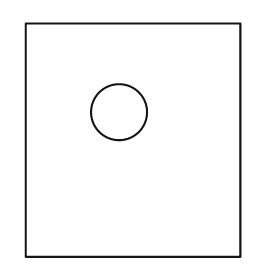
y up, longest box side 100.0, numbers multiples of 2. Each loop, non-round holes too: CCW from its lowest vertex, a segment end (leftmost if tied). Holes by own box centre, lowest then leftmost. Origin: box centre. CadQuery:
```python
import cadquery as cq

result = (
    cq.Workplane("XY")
    .moveTo(-46.0, -50.0)
    .lineTo(46.0, -50.0)
    .lineTo(46.0, 50.0)
    .lineTo(-46.0, 50.0)
    .close()
    .moveTo(-6.0, 12.0)
    .circle(12.0)
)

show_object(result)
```